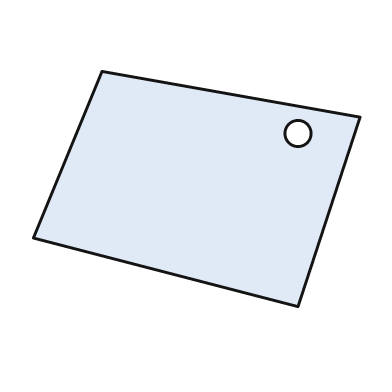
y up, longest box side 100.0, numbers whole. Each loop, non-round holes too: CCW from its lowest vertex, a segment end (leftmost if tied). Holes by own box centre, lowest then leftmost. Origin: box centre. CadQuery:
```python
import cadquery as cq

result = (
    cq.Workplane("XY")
    .moveTo(31.0, -36.0)
    .lineTo(50.0, 22.0)
    .lineTo(-29.0, 36.0)
    .lineTo(-50.0, -15.0)
    .close()
    .moveTo(31.0, 17.0)
    .circle(4.0)
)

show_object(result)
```